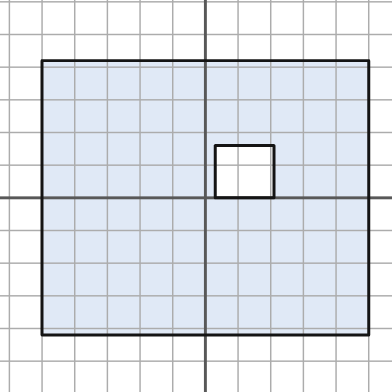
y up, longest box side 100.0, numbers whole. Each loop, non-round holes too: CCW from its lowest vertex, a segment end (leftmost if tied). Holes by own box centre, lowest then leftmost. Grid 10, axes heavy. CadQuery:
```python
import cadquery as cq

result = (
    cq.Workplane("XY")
    .moveTo(-50.0, -42.0)
    .lineTo(50.0, -42.0)
    .lineTo(50.0, 42.0)
    .lineTo(-50.0, 42.0)
    .close()
    .moveTo(3.0, 0.0)
    .lineTo(21.0, 0.0)
    .lineTo(21.0, 16.0)
    .lineTo(3.0, 16.0)
    .close()
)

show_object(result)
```